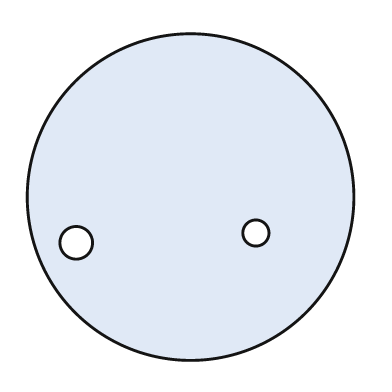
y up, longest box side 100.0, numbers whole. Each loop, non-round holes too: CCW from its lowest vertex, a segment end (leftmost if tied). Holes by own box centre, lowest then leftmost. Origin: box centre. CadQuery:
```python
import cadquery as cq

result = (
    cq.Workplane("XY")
    .moveTo(0.0, 0.0)
    .circle(50.0)
    .moveTo(-35.0, -14.0)
    .circle(5.0)
    .moveTo(20.0, -11.0)
    .circle(4.0)
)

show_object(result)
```